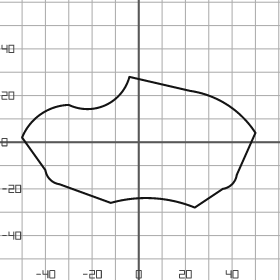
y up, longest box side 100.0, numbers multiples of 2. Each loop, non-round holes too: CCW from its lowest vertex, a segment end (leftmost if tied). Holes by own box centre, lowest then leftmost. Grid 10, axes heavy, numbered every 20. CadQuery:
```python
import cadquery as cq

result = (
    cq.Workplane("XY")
    .moveTo(24.0, -28.0)
    .lineTo(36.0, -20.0)
    .threePointArc((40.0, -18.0), (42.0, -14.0))
    .lineTo(50.0, 4.0)
    .threePointArc((38.0, 16.0), (22.0, 22.0))
    .lineTo(-4.0, 28.0)
    .threePointArc((-14.0, 16.0), (-30.0, 16.0))
    .threePointArc((-42.0, 12.0), (-50.0, 2.0))
    .lineTo(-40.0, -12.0)
    .threePointArc((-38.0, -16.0), (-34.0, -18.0))
    .lineTo(-12.0, -26.0)
    .threePointArc((6.0, -24.0), (24.0, -28.0))
    .close()
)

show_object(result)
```